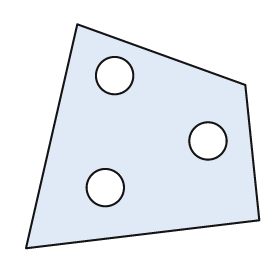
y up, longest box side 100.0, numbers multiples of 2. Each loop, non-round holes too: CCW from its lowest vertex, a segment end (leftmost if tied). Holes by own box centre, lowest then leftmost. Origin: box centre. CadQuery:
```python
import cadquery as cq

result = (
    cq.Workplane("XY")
    .moveTo(-50.0, -48.0)
    .lineTo(50.0, -36.0)
    .lineTo(44.0, 22.0)
    .lineTo(-28.0, 48.0)
    .close()
    .moveTo(-16.0, -22.0)
    .circle(8.0)
    .moveTo(28.0, -2.0)
    .circle(8.0)
    .moveTo(-12.0, 26.0)
    .circle(8.0)
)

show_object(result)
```